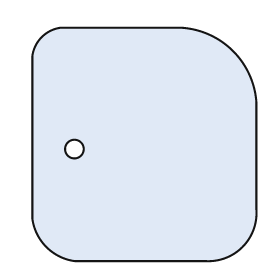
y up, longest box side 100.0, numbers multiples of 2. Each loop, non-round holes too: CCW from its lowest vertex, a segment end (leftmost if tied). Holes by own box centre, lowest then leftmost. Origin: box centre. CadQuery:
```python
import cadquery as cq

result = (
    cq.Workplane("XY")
    .moveTo(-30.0, -50.0)
    .lineTo(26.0, -50.0)
    .threePointArc((42.0, -44.0), (48.0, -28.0))
    .lineTo(48.0, 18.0)
    .threePointArc((38.0, 40.0), (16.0, 50.0))
    .lineTo(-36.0, 50.0)
    .threePointArc((-44.0, 46.0), (-48.0, 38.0))
    .lineTo(-48.0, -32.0)
    .threePointArc((-42.0, -44.0), (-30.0, -50.0))
    .close()
    .moveTo(-30.0, -2.0)
    .circle(4.0)
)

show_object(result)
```